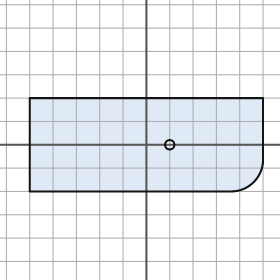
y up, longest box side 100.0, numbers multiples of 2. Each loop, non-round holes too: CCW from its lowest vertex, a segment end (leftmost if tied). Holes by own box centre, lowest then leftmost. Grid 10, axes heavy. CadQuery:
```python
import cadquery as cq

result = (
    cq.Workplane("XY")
    .moveTo(-50.0, -20.0)
    .lineTo(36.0, -20.0)
    .threePointArc((46.0, -16.0), (50.0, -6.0))
    .lineTo(50.0, 20.0)
    .lineTo(-50.0, 20.0)
    .close()
    .moveTo(10.0, 0.0)
    .circle(2.0)
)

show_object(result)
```